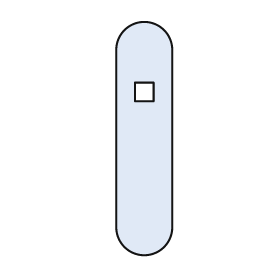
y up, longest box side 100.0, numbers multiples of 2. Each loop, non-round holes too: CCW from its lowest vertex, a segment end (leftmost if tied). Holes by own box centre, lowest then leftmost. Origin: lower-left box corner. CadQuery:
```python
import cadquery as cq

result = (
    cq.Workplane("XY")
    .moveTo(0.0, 12.0)
    .threePointArc((12.0, 0.0), (24.0, 12.0))
    .lineTo(24.0, 88.0)
    .threePointArc((12.0, 100.0), (0.0, 88.0))
    .close()
    .moveTo(8.0, 66.0)
    .lineTo(16.0, 66.0)
    .lineTo(16.0, 74.0)
    .lineTo(8.0, 74.0)
    .close()
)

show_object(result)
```